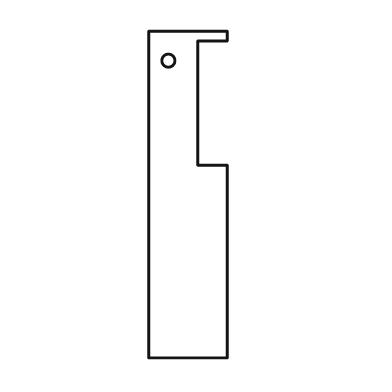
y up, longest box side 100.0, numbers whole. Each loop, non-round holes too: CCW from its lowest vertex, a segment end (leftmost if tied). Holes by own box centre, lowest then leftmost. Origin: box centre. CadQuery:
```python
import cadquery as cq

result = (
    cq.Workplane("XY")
    .moveTo(-12.0, -50.0)
    .lineTo(12.0, -50.0)
    .lineTo(12.0, 9.0)
    .lineTo(3.0, 9.0)
    .lineTo(3.0, 47.0)
    .lineTo(12.0, 47.0)
    .lineTo(12.0, 50.0)
    .lineTo(-12.0, 50.0)
    .close()
    .moveTo(-6.0, 41.0)
    .circle(2.0)
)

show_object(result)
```